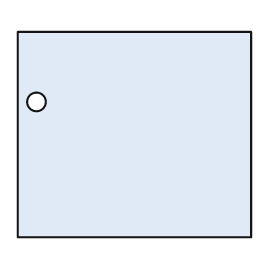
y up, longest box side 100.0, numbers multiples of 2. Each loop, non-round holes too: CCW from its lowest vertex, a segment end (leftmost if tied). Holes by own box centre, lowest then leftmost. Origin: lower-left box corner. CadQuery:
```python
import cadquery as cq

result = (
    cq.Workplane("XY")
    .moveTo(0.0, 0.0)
    .lineTo(100.0, 0.0)
    .lineTo(100.0, 88.0)
    .lineTo(0.0, 88.0)
    .close()
    .moveTo(8.0, 58.0)
    .circle(4.0)
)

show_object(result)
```